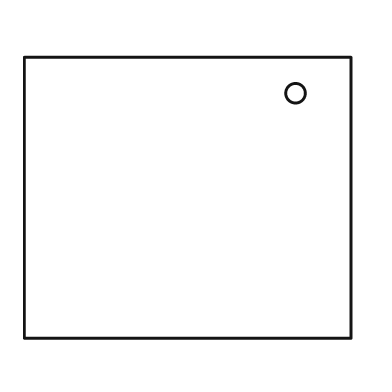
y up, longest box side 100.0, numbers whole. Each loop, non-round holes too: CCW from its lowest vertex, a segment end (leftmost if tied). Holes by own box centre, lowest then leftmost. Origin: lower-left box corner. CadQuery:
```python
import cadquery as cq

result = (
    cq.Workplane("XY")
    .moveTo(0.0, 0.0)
    .lineTo(100.0, 0.0)
    .lineTo(100.0, 86.0)
    .lineTo(0.0, 86.0)
    .close()
    .moveTo(83.0, 75.0)
    .circle(3.0)
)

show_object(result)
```